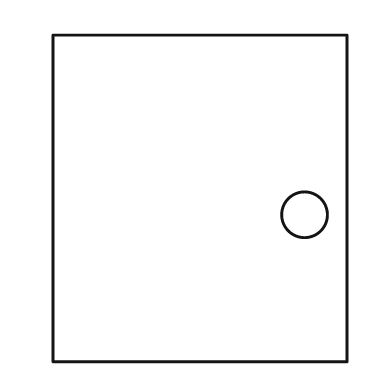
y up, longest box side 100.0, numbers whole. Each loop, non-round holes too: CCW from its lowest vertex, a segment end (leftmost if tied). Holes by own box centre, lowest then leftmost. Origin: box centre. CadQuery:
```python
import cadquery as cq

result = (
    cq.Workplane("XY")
    .moveTo(-45.0, -50.0)
    .lineTo(45.0, -50.0)
    .lineTo(45.0, 50.0)
    .lineTo(-45.0, 50.0)
    .close()
    .moveTo(32.0, -5.0)
    .circle(7.0)
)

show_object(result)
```